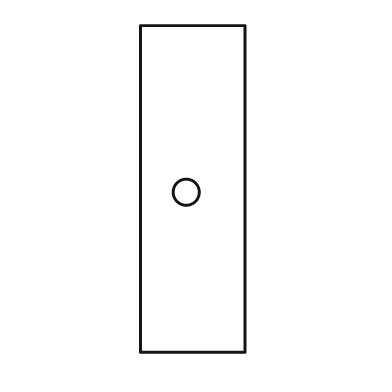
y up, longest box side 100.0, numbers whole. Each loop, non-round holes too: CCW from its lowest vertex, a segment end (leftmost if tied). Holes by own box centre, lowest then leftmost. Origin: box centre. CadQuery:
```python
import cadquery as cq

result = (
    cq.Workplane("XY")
    .moveTo(-16.0, -50.0)
    .lineTo(16.0, -50.0)
    .lineTo(16.0, 50.0)
    .lineTo(-16.0, 50.0)
    .close()
    .moveTo(-2.0, -1.0)
    .circle(4.0)
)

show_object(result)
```